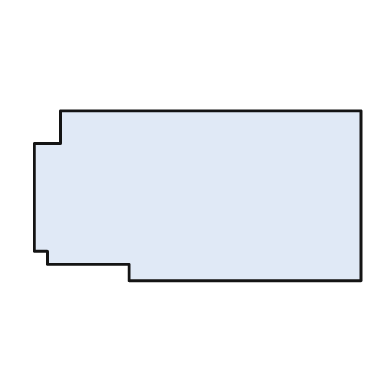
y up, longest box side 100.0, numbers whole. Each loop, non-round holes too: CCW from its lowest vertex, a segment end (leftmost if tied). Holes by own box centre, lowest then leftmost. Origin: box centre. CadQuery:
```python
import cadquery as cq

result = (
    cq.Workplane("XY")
    .moveTo(-21.0, -26.0)
    .lineTo(50.0, -26.0)
    .lineTo(50.0, 26.0)
    .lineTo(-42.0, 26.0)
    .lineTo(-42.0, 16.0)
    .lineTo(-50.0, 16.0)
    .lineTo(-50.0, -17.0)
    .lineTo(-46.0, -17.0)
    .lineTo(-46.0, -21.0)
    .lineTo(-21.0, -21.0)
    .close()
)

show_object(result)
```